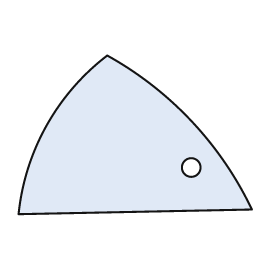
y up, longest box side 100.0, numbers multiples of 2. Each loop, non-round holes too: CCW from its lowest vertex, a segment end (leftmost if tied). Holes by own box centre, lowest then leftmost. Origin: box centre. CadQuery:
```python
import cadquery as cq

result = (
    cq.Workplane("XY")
    .moveTo(-50.0, -34.0)
    .lineTo(50.0, -32.0)
    .threePointArc((24.0, 6.0), (-12.0, 34.0))
    .threePointArc((-38.0, 4.0), (-50.0, -34.0))
    .close()
    .moveTo(24.0, -14.0)
    .circle(4.0)
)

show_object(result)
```